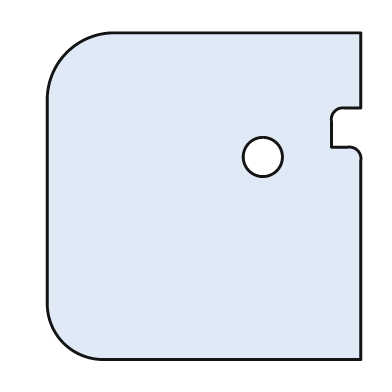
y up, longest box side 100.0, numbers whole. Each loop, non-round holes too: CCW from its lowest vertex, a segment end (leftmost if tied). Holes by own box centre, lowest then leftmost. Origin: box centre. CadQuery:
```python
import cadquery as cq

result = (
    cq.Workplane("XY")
    .moveTo(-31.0, -50.0)
    .lineTo(48.0, -50.0)
    .lineTo(48.0, 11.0)
    .threePointArc((47.0, 14.0), (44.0, 15.0))
    .lineTo(39.0, 15.0)
    .lineTo(39.0, 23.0)
    .threePointArc((40.0, 26.0), (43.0, 27.0))
    .lineTo(48.0, 27.0)
    .lineTo(48.0, 50.0)
    .lineTo(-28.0, 50.0)
    .threePointArc((-42.0, 44.0), (-48.0, 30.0))
    .lineTo(-48.0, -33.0)
    .threePointArc((-43.0, -45.0), (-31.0, -50.0))
    .close()
    .moveTo(18.0, 12.0)
    .circle(6.0)
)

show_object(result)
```